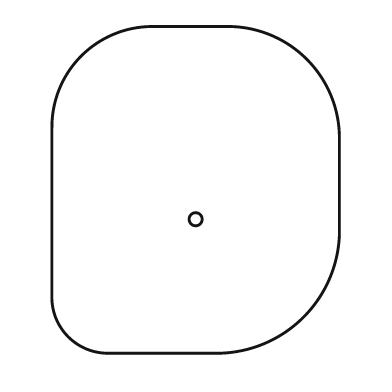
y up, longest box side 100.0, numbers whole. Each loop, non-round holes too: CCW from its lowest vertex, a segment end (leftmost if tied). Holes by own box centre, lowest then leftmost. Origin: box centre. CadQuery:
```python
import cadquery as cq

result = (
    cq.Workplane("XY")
    .moveTo(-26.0, -50.0)
    .lineTo(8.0, -50.0)
    .threePointArc((33.0, -39.0), (44.0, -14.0))
    .lineTo(44.0, 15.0)
    .threePointArc((34.0, 40.0), (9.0, 50.0))
    .lineTo(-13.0, 50.0)
    .threePointArc((-35.0, 41.0), (-44.0, 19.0))
    .lineTo(-44.0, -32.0)
    .threePointArc((-39.0, -45.0), (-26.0, -50.0))
    .close()
    .moveTo(0.0, -9.0)
    .circle(2.0)
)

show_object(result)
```